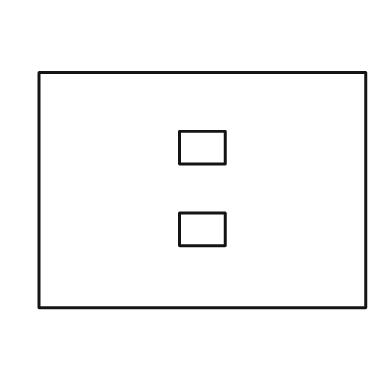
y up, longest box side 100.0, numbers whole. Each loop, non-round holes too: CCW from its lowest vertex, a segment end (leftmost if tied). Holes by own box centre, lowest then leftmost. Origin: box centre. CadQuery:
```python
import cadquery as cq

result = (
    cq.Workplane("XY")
    .moveTo(-50.0, -36.0)
    .lineTo(50.0, -36.0)
    .lineTo(50.0, 36.0)
    .lineTo(-50.0, 36.0)
    .close()
    .moveTo(-7.0, -17.0)
    .lineTo(7.0, -17.0)
    .lineTo(7.0, -7.0)
    .lineTo(-7.0, -7.0)
    .close()
    .moveTo(-7.0, 8.0)
    .lineTo(7.0, 8.0)
    .lineTo(7.0, 18.0)
    .lineTo(-7.0, 18.0)
    .close()
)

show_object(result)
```